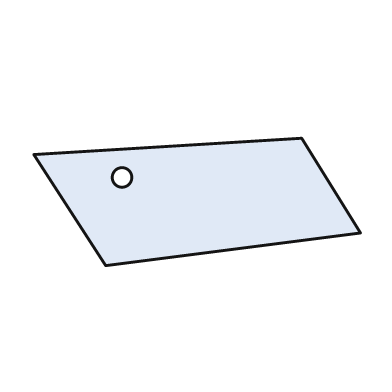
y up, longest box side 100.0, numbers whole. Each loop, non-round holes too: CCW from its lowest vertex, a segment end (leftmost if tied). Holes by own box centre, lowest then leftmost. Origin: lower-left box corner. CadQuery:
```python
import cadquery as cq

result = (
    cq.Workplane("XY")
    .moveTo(22.0, 0.0)
    .lineTo(100.0, 10.0)
    .lineTo(82.0, 39.0)
    .lineTo(0.0, 34.0)
    .close()
    .moveTo(27.0, 27.0)
    .circle(3.0)
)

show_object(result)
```